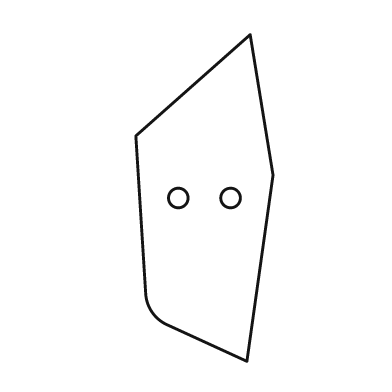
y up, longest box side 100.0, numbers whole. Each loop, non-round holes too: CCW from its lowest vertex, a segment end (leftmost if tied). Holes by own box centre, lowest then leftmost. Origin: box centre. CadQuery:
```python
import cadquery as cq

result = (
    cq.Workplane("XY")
    .moveTo(13.0, -50.0)
    .lineTo(21.0, 7.0)
    .lineTo(14.0, 50.0)
    .lineTo(-21.0, 19.0)
    .lineTo(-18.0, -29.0)
    .threePointArc((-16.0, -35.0), (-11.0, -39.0))
    .close()
    .moveTo(-8.0, 0.0)
    .circle(3.0)
    .moveTo(8.0, 0.0)
    .circle(3.0)
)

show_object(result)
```